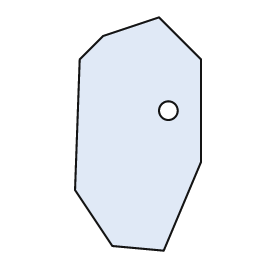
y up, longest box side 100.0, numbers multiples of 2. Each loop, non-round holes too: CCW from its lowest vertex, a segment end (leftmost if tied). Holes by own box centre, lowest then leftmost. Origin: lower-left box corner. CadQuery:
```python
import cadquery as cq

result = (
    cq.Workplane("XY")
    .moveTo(38.0, 0.0)
    .lineTo(54.0, 38.0)
    .lineTo(54.0, 82.0)
    .lineTo(36.0, 100.0)
    .lineTo(12.0, 92.0)
    .lineTo(2.0, 82.0)
    .lineTo(0.0, 26.0)
    .lineTo(16.0, 2.0)
    .close()
    .moveTo(40.0, 60.0)
    .circle(4.0)
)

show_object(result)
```